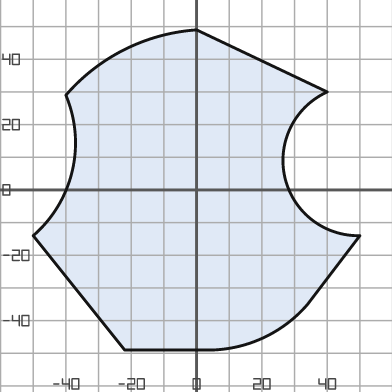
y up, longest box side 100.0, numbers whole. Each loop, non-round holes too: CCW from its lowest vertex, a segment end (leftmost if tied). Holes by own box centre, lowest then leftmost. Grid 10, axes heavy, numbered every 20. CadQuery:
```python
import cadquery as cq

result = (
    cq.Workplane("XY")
    .moveTo(-22.0, -49.0)
    .lineTo(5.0, -49.0)
    .threePointArc((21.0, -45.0), (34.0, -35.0))
    .lineTo(50.0, -14.0)
    .threePointArc((27.0, 4.0), (40.0, 30.0))
    .lineTo(0.0, 49.0)
    .threePointArc((-22.0, 43.0), (-40.0, 29.0))
    .threePointArc((-38.0, 6.0), (-50.0, -14.0))
    .close()
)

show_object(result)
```